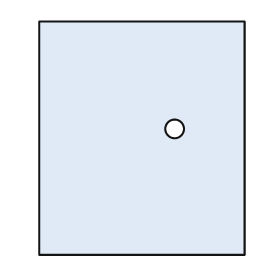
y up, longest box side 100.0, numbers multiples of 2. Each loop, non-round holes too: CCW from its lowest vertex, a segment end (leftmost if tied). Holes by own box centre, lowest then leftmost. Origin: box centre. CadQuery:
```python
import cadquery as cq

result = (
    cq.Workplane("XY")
    .moveTo(-44.0, -50.0)
    .lineTo(44.0, -50.0)
    .lineTo(44.0, 50.0)
    .lineTo(-44.0, 50.0)
    .close()
    .moveTo(14.0, 4.0)
    .circle(4.0)
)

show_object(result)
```